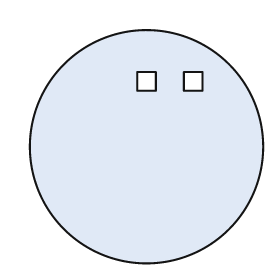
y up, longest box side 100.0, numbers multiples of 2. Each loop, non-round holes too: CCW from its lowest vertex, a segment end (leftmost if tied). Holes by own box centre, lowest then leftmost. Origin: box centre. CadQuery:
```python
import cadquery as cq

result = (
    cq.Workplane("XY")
    .moveTo(0.0, 0.0)
    .circle(50.0)
    .moveTo(-4.0, 24.0)
    .lineTo(4.0, 24.0)
    .lineTo(4.0, 32.0)
    .lineTo(-4.0, 32.0)
    .close()
    .moveTo(16.0, 24.0)
    .lineTo(24.0, 24.0)
    .lineTo(24.0, 32.0)
    .lineTo(16.0, 32.0)
    .close()
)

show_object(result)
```